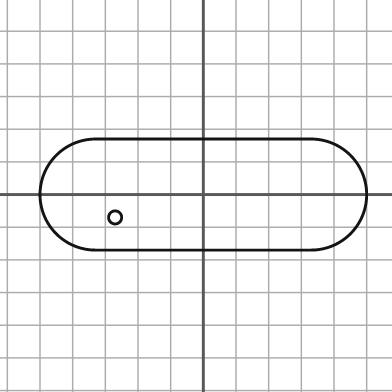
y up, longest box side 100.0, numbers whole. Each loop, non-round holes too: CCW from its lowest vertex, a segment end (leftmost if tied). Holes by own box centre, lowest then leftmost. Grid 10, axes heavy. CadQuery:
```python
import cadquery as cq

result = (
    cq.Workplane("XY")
    .moveTo(-33.0, -17.0)
    .lineTo(33.0, -17.0)
    .threePointArc((50.0, 0.0), (33.0, 17.0))
    .lineTo(-33.0, 17.0)
    .threePointArc((-50.0, 0.0), (-33.0, -17.0))
    .close()
    .moveTo(-27.0, -7.0)
    .circle(2.0)
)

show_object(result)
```